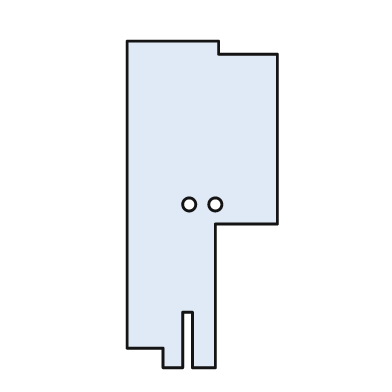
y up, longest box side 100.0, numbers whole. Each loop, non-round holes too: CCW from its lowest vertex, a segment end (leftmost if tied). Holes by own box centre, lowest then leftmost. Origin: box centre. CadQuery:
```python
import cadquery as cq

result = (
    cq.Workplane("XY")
    .moveTo(-12.0, -50.0)
    .lineTo(-6.0, -50.0)
    .lineTo(-6.0, -33.0)
    .lineTo(-3.0, -33.0)
    .lineTo(-3.0, -50.0)
    .lineTo(4.0, -50.0)
    .lineTo(4.0, -6.0)
    .lineTo(23.0, -6.0)
    .lineTo(23.0, 46.0)
    .lineTo(5.0, 46.0)
    .lineTo(5.0, 50.0)
    .lineTo(-23.0, 50.0)
    .lineTo(-23.0, -44.0)
    .lineTo(-12.0, -44.0)
    .close()
    .moveTo(-4.0, 0.0)
    .circle(2.0)
    .moveTo(4.0, 0.0)
    .circle(2.0)
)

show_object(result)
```